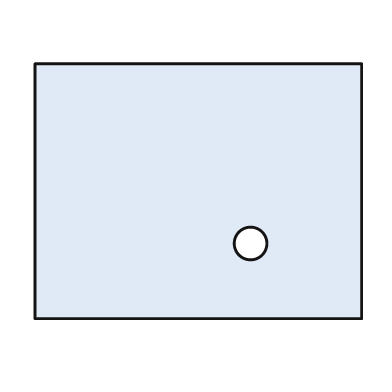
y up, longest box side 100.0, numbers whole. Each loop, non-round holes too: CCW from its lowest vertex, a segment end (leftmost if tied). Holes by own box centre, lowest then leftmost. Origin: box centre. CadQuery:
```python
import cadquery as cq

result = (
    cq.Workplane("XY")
    .moveTo(-50.0, -39.0)
    .lineTo(50.0, -39.0)
    .lineTo(50.0, 39.0)
    .lineTo(-50.0, 39.0)
    .close()
    .moveTo(16.0, -16.0)
    .circle(5.0)
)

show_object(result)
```